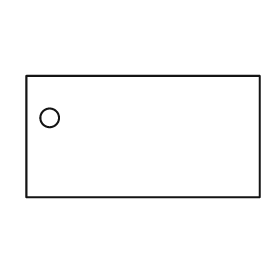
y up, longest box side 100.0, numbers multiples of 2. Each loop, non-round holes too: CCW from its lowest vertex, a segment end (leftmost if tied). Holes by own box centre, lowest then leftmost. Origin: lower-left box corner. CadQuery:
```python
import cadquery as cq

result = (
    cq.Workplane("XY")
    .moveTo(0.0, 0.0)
    .lineTo(100.0, 0.0)
    .lineTo(100.0, 52.0)
    .lineTo(0.0, 52.0)
    .close()
    .moveTo(10.0, 34.0)
    .circle(4.0)
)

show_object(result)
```